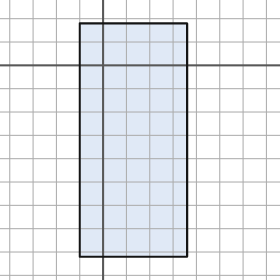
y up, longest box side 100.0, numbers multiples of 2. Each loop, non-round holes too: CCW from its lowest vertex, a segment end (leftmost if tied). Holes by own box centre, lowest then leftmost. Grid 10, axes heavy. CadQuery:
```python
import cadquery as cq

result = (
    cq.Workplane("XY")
    .moveTo(-10.0, -82.0)
    .lineTo(36.0, -82.0)
    .lineTo(36.0, 18.0)
    .lineTo(-10.0, 18.0)
    .close()
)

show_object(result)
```